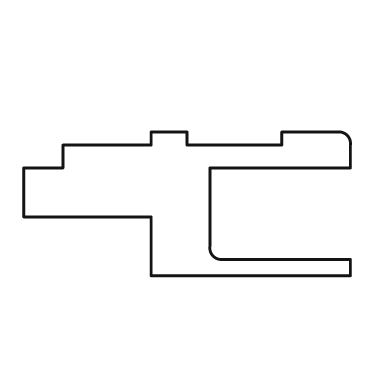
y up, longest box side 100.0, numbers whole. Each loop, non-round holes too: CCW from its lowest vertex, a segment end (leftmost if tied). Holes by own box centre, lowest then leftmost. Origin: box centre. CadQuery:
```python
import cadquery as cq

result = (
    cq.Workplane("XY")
    .moveTo(-11.0, -22.0)
    .lineTo(50.0, -22.0)
    .lineTo(50.0, -17.0)
    .lineTo(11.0, -17.0)
    .threePointArc((8.0, -16.0), (7.0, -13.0))
    .lineTo(7.0, 11.0)
    .lineTo(50.0, 11.0)
    .lineTo(50.0, 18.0)
    .threePointArc((49.0, 21.0), (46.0, 22.0))
    .lineTo(29.0, 22.0)
    .lineTo(29.0, 18.0)
    .lineTo(0.0, 18.0)
    .lineTo(0.0, 22.0)
    .lineTo(-11.0, 22.0)
    .lineTo(-11.0, 18.0)
    .lineTo(-38.0, 18.0)
    .lineTo(-38.0, 11.0)
    .lineTo(-50.0, 11.0)
    .lineTo(-50.0, -4.0)
    .lineTo(-11.0, -4.0)
    .close()
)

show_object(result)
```